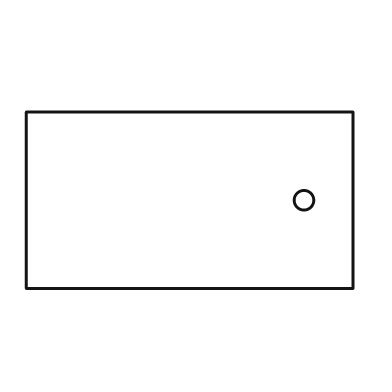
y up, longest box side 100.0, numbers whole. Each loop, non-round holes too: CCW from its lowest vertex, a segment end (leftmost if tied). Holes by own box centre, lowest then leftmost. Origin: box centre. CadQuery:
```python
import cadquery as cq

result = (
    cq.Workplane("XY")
    .moveTo(-50.0, -27.0)
    .lineTo(50.0, -27.0)
    .lineTo(50.0, 27.0)
    .lineTo(-50.0, 27.0)
    .close()
    .moveTo(35.0, 0.0)
    .circle(3.0)
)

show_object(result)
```